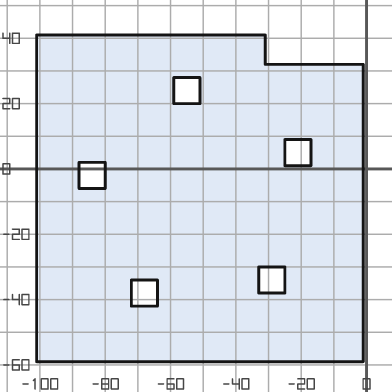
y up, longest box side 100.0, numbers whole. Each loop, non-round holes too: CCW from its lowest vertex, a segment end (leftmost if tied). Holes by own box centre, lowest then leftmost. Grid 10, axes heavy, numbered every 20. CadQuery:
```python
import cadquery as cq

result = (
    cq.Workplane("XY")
    .moveTo(-101.0, -59.0)
    .lineTo(-1.0, -59.0)
    .lineTo(-1.0, 32.0)
    .lineTo(-31.0, 32.0)
    .lineTo(-31.0, 41.0)
    .lineTo(-101.0, 41.0)
    .close()
    .moveTo(-72.0, -42.0)
    .lineTo(-64.0, -42.0)
    .lineTo(-64.0, -34.0)
    .lineTo(-72.0, -34.0)
    .close()
    .moveTo(-33.0, -38.0)
    .lineTo(-25.0, -38.0)
    .lineTo(-25.0, -30.0)
    .lineTo(-33.0, -30.0)
    .close()
    .moveTo(-88.0, -6.0)
    .lineTo(-80.0, -6.0)
    .lineTo(-80.0, 2.0)
    .lineTo(-88.0, 2.0)
    .close()
    .moveTo(-25.0, 1.0)
    .lineTo(-17.0, 1.0)
    .lineTo(-17.0, 9.0)
    .lineTo(-25.0, 9.0)
    .close()
    .moveTo(-59.0, 20.0)
    .lineTo(-51.0, 20.0)
    .lineTo(-51.0, 28.0)
    .lineTo(-59.0, 28.0)
    .close()
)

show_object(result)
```